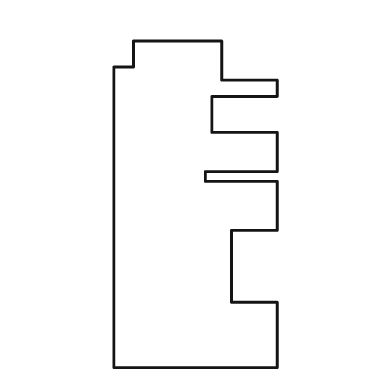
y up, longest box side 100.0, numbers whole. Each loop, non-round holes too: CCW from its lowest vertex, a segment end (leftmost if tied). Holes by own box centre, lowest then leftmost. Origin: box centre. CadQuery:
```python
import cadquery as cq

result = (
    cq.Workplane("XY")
    .moveTo(-25.0, -50.0)
    .lineTo(25.0, -50.0)
    .lineTo(25.0, -30.0)
    .lineTo(11.0, -30.0)
    .lineTo(11.0, -8.0)
    .lineTo(25.0, -8.0)
    .lineTo(25.0, 7.0)
    .lineTo(3.0, 7.0)
    .lineTo(3.0, 10.0)
    .lineTo(25.0, 10.0)
    .lineTo(25.0, 22.0)
    .lineTo(5.0, 22.0)
    .lineTo(5.0, 33.0)
    .lineTo(25.0, 33.0)
    .lineTo(25.0, 38.0)
    .lineTo(8.0, 38.0)
    .lineTo(8.0, 50.0)
    .lineTo(-19.0, 50.0)
    .lineTo(-19.0, 42.0)
    .lineTo(-25.0, 42.0)
    .close()
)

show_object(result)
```